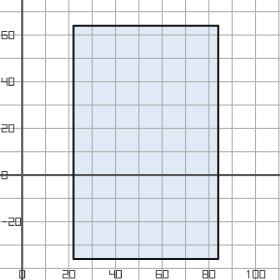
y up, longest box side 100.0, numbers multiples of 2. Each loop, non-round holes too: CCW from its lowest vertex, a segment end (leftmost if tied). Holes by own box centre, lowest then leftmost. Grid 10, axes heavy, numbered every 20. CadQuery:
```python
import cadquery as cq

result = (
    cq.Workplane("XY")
    .moveTo(22.0, -36.0)
    .lineTo(84.0, -36.0)
    .lineTo(84.0, 64.0)
    .lineTo(22.0, 64.0)
    .close()
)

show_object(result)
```